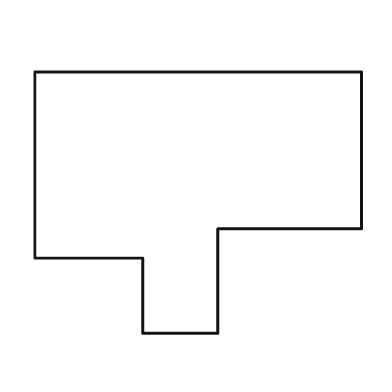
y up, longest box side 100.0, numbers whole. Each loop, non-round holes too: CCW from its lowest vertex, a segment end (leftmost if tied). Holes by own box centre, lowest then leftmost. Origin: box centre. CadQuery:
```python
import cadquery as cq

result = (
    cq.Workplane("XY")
    .moveTo(-17.0, -40.0)
    .lineTo(6.0, -40.0)
    .lineTo(6.0, -8.0)
    .lineTo(50.0, -8.0)
    .lineTo(50.0, 40.0)
    .lineTo(-50.0, 40.0)
    .lineTo(-50.0, -17.0)
    .lineTo(-17.0, -17.0)
    .close()
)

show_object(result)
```